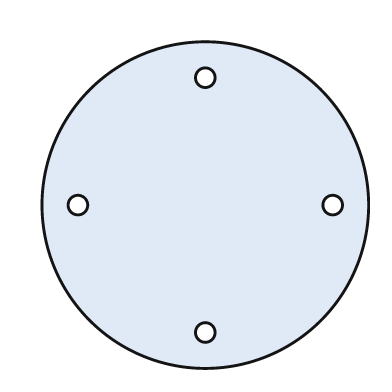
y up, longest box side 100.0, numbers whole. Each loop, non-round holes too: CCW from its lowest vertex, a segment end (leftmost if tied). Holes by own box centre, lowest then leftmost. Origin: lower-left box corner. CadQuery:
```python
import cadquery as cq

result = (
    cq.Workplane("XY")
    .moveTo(50.0, 50.0)
    .circle(50.0)
    .moveTo(50.0, 11.0)
    .circle(3.0)
    .moveTo(11.0, 50.0)
    .circle(3.0)
    .moveTo(89.0, 50.0)
    .circle(3.0)
    .moveTo(50.0, 89.0)
    .circle(3.0)
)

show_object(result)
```